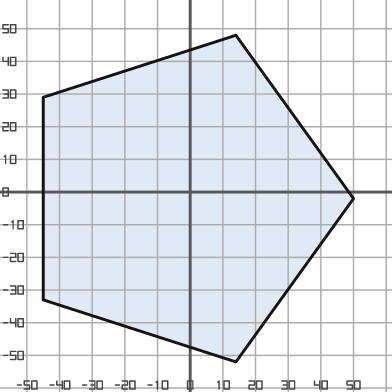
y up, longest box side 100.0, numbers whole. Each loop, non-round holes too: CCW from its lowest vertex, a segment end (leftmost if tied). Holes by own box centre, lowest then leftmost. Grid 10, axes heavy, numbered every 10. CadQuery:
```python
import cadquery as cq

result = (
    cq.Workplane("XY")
    .moveTo(14.0, -52.0)
    .lineTo(50.0, -2.0)
    .lineTo(14.0, 48.0)
    .lineTo(-45.0, 29.0)
    .lineTo(-45.0, -33.0)
    .close()
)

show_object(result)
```